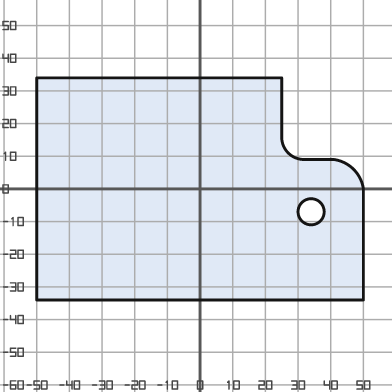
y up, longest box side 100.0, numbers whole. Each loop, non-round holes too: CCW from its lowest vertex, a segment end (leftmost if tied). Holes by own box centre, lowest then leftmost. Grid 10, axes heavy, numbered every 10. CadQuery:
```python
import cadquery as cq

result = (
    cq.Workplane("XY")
    .moveTo(-50.0, -34.0)
    .lineTo(50.0, -34.0)
    .lineTo(50.0, 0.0)
    .threePointArc((47.0, 6.0), (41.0, 9.0))
    .lineTo(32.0, 9.0)
    .threePointArc((27.0, 11.0), (25.0, 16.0))
    .lineTo(25.0, 34.0)
    .lineTo(-50.0, 34.0)
    .close()
    .moveTo(34.0, -7.0)
    .circle(4.0)
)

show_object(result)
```